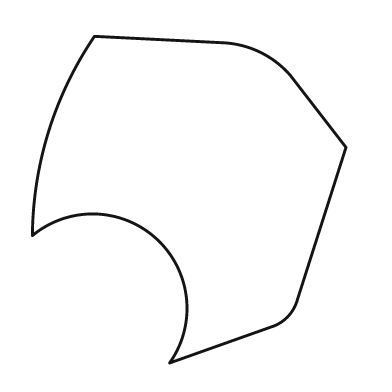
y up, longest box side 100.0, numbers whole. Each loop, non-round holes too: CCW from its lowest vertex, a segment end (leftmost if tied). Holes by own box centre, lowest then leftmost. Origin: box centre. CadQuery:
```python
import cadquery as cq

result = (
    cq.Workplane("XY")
    .moveTo(-6.0, -50.0)
    .lineTo(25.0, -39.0)
    .threePointArc((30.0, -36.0), (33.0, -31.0))
    .lineTo(48.0, 16.0)
    .lineTo(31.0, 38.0)
    .threePointArc((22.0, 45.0), (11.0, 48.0))
    .lineTo(-29.0, 50.0)
    .threePointArc((-43.0, 21.0), (-48.0, -11.0))
    .threePointArc((-10.0, -12.0), (-6.0, -50.0))
    .close()
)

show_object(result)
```